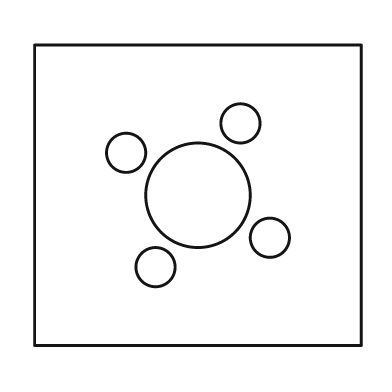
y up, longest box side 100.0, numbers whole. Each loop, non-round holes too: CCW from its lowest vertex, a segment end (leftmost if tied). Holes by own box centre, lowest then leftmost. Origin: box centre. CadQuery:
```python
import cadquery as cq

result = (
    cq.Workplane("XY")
    .moveTo(-50.0, -46.0)
    .lineTo(50.0, -46.0)
    .lineTo(50.0, 46.0)
    .lineTo(-50.0, 46.0)
    .close()
    .moveTo(-13.0, -22.0)
    .circle(6.0)
    .moveTo(22.0, -13.0)
    .circle(6.0)
    .moveTo(0.0, 0.0)
    .circle(16.0)
    .moveTo(-22.0, 13.0)
    .circle(6.0)
    .moveTo(13.0, 22.0)
    .circle(6.0)
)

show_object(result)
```